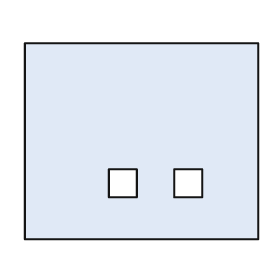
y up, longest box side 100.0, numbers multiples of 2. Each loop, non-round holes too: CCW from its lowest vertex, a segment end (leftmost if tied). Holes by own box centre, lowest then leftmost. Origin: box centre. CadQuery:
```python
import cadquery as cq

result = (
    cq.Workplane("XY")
    .moveTo(-50.0, -42.0)
    .lineTo(50.0, -42.0)
    .lineTo(50.0, 42.0)
    .lineTo(-50.0, 42.0)
    .close()
    .moveTo(-14.0, -24.0)
    .lineTo(-2.0, -24.0)
    .lineTo(-2.0, -12.0)
    .lineTo(-14.0, -12.0)
    .close()
    .moveTo(14.0, -24.0)
    .lineTo(26.0, -24.0)
    .lineTo(26.0, -12.0)
    .lineTo(14.0, -12.0)
    .close()
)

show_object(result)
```